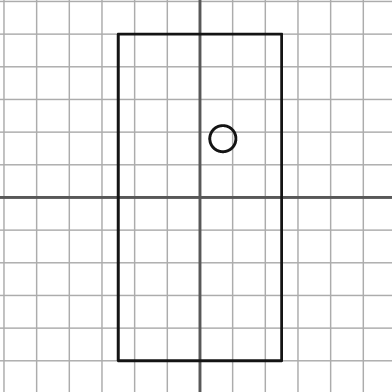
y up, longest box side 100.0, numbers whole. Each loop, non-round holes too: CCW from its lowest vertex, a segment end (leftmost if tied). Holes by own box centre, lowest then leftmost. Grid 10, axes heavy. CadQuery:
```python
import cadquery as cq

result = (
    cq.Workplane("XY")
    .moveTo(-25.0, -50.0)
    .lineTo(25.0, -50.0)
    .lineTo(25.0, 50.0)
    .lineTo(-25.0, 50.0)
    .close()
    .moveTo(7.0, 18.0)
    .circle(4.0)
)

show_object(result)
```